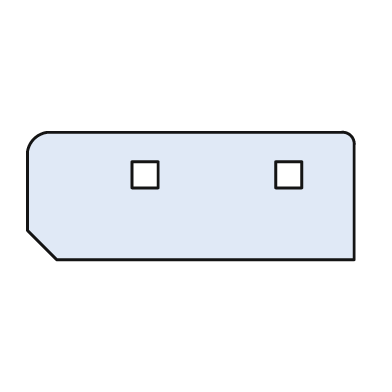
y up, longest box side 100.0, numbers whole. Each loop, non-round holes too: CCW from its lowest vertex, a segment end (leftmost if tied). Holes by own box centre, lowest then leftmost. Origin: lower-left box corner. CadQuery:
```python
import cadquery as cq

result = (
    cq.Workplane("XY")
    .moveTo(9.0, 0.0)
    .lineTo(100.0, 0.0)
    .lineTo(100.0, 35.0)
    .threePointArc((99.0, 38.0), (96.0, 39.0))
    .lineTo(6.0, 39.0)
    .threePointArc((2.0, 37.0), (0.0, 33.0))
    .lineTo(0.0, 9.0)
    .close()
    .moveTo(32.0, 22.0)
    .lineTo(40.0, 22.0)
    .lineTo(40.0, 30.0)
    .lineTo(32.0, 30.0)
    .close()
    .moveTo(76.0, 22.0)
    .lineTo(84.0, 22.0)
    .lineTo(84.0, 30.0)
    .lineTo(76.0, 30.0)
    .close()
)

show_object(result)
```